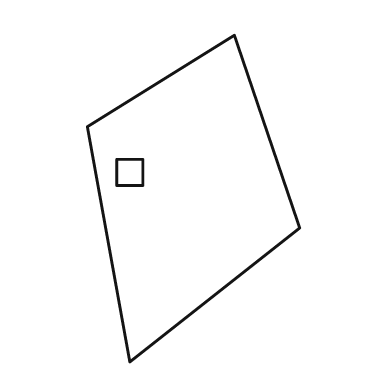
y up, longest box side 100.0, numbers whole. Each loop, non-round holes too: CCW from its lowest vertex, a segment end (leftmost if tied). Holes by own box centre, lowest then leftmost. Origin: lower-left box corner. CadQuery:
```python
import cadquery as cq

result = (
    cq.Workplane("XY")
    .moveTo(13.0, 0.0)
    .lineTo(65.0, 41.0)
    .lineTo(45.0, 100.0)
    .lineTo(0.0, 72.0)
    .close()
    .moveTo(9.0, 54.0)
    .lineTo(17.0, 54.0)
    .lineTo(17.0, 62.0)
    .lineTo(9.0, 62.0)
    .close()
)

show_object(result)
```